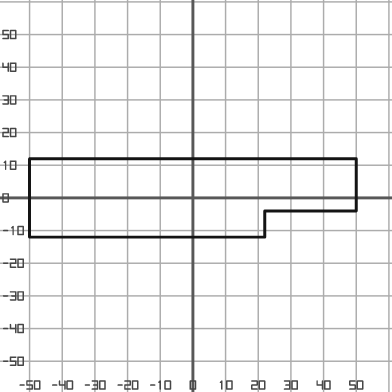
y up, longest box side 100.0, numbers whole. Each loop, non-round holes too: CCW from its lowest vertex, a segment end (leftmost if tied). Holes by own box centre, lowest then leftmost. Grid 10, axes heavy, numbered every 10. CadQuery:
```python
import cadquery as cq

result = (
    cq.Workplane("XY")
    .moveTo(-50.0, -12.0)
    .lineTo(22.0, -12.0)
    .lineTo(22.0, -4.0)
    .lineTo(50.0, -4.0)
    .lineTo(50.0, 12.0)
    .lineTo(-50.0, 12.0)
    .close()
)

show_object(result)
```